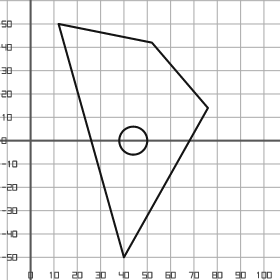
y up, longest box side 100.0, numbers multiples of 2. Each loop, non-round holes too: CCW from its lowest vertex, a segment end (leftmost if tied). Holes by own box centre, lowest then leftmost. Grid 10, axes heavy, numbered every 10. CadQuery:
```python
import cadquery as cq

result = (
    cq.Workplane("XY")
    .moveTo(40.0, -50.0)
    .lineTo(76.0, 14.0)
    .lineTo(52.0, 42.0)
    .lineTo(12.0, 50.0)
    .close()
    .moveTo(44.0, 0.0)
    .circle(6.0)
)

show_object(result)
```